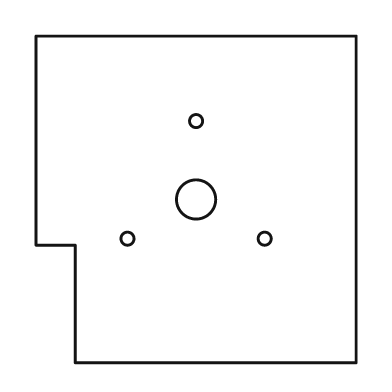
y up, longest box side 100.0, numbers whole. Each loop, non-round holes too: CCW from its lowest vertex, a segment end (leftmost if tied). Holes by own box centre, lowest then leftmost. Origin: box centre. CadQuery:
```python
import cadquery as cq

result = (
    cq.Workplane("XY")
    .moveTo(-37.0, -50.0)
    .lineTo(49.0, -50.0)
    .lineTo(49.0, 50.0)
    .lineTo(-49.0, 50.0)
    .lineTo(-49.0, -14.0)
    .lineTo(-37.0, -14.0)
    .close()
    .moveTo(-21.0, -12.0)
    .circle(2.0)
    .moveTo(21.0, -12.0)
    .circle(2.0)
    .moveTo(0.0, 0.0)
    .circle(6.0)
    .moveTo(0.0, 24.0)
    .circle(2.0)
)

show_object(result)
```